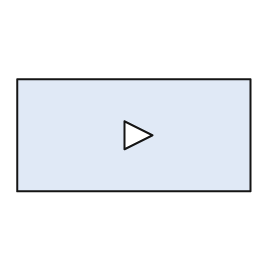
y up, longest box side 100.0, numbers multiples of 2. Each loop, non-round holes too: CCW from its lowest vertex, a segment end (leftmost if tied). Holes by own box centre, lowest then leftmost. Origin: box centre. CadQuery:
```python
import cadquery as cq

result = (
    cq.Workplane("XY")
    .moveTo(-50.0, -24.0)
    .lineTo(50.0, -24.0)
    .lineTo(50.0, 24.0)
    .lineTo(-50.0, 24.0)
    .close()
    .moveTo(-4.0, -6.0)
    .lineTo(8.0, 0.0)
    .lineTo(-4.0, 6.0)
    .close()
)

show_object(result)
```